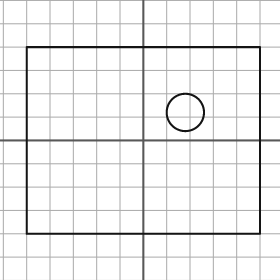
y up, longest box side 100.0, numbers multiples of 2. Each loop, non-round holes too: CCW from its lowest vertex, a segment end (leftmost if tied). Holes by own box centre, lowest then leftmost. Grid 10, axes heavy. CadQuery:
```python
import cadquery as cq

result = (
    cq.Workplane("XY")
    .moveTo(-50.0, -40.0)
    .lineTo(50.0, -40.0)
    .lineTo(50.0, 40.0)
    .lineTo(-50.0, 40.0)
    .close()
    .moveTo(18.0, 12.0)
    .circle(8.0)
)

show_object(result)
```